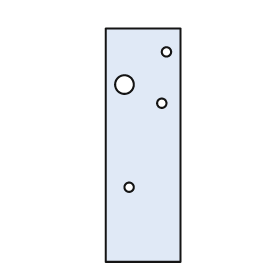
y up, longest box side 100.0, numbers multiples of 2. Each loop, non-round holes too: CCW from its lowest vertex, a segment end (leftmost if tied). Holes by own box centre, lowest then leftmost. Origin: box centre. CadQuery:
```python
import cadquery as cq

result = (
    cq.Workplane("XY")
    .moveTo(-16.0, -50.0)
    .lineTo(16.0, -50.0)
    .lineTo(16.0, 50.0)
    .lineTo(-16.0, 50.0)
    .close()
    .moveTo(-6.0, -18.0)
    .circle(2.0)
    .moveTo(8.0, 18.0)
    .circle(2.0)
    .moveTo(-8.0, 26.0)
    .circle(4.0)
    .moveTo(10.0, 40.0)
    .circle(2.0)
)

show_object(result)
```